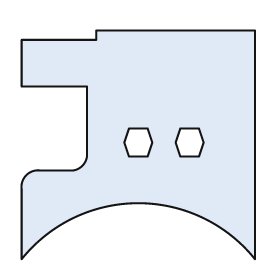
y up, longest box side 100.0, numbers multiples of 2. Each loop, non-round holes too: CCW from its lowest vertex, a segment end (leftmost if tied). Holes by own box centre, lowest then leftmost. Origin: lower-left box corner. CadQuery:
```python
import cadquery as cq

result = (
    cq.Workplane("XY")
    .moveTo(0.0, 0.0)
    .threePointArc((50.0, 24.0), (100.0, 0.0))
    .lineTo(100.0, 98.0)
    .lineTo(32.0, 98.0)
    .lineTo(32.0, 94.0)
    .lineTo(0.0, 94.0)
    .lineTo(0.0, 74.0)
    .lineTo(28.0, 74.0)
    .lineTo(28.0, 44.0)
    .threePointArc((26.0, 40.0), (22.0, 38.0))
    .lineTo(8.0, 38.0)
    .threePointArc((2.0, 36.0), (0.0, 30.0))
    .close()
    .moveTo(46.0, 44.0)
    .lineTo(54.0, 44.0)
    .lineTo(56.0, 50.0)
    .lineTo(54.0, 56.0)
    .lineTo(46.0, 56.0)
    .lineTo(44.0, 50.0)
    .close()
    .moveTo(68.0, 44.0)
    .lineTo(76.0, 44.0)
    .lineTo(78.0, 50.0)
    .lineTo(76.0, 56.0)
    .lineTo(68.0, 56.0)
    .lineTo(66.0, 50.0)
    .close()
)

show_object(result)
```